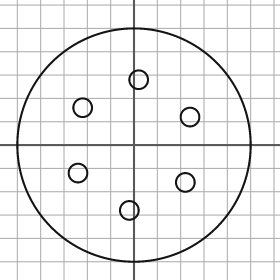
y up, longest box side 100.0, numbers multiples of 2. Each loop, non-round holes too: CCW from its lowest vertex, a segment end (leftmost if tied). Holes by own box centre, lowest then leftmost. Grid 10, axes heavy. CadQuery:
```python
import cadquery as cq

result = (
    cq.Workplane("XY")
    .moveTo(0.0, 0.0)
    .circle(50.0)
    .moveTo(-2.0, -28.0)
    .circle(4.0)
    .moveTo(22.0, -16.0)
    .circle(4.0)
    .moveTo(-24.0, -12.0)
    .circle(4.0)
    .moveTo(24.0, 12.0)
    .circle(4.0)
    .moveTo(-22.0, 16.0)
    .circle(4.0)
    .moveTo(2.0, 28.0)
    .circle(4.0)
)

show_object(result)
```